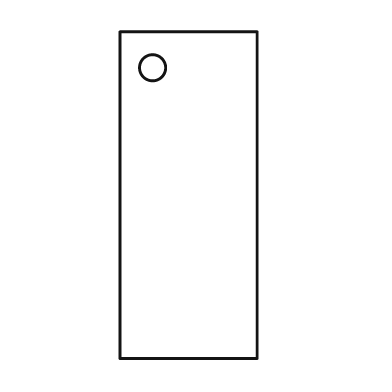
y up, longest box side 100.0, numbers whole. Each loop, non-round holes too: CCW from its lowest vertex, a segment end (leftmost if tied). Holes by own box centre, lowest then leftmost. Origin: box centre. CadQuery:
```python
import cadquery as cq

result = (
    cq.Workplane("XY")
    .moveTo(-21.0, -50.0)
    .lineTo(21.0, -50.0)
    .lineTo(21.0, 50.0)
    .lineTo(-21.0, 50.0)
    .close()
    .moveTo(-11.0, 39.0)
    .circle(4.0)
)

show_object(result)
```